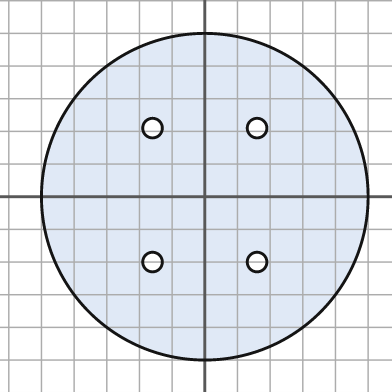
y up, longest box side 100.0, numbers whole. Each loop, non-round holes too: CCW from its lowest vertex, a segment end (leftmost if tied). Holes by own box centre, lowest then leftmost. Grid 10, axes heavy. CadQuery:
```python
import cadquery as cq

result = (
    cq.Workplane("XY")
    .moveTo(0.0, 0.0)
    .circle(50.0)
    .moveTo(-16.0, -20.0)
    .circle(3.0)
    .moveTo(16.0, -20.0)
    .circle(3.0)
    .moveTo(-16.0, 21.0)
    .circle(3.0)
    .moveTo(16.0, 21.0)
    .circle(3.0)
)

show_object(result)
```